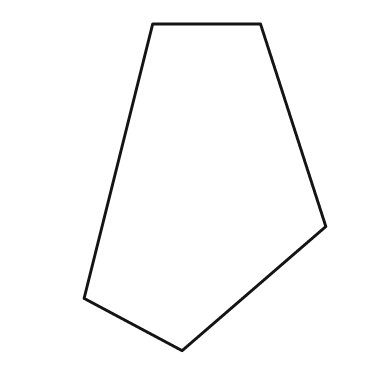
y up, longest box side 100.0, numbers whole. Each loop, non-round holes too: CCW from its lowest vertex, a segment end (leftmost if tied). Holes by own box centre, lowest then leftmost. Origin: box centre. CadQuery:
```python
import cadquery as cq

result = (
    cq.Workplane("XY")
    .moveTo(-7.0, -50.0)
    .lineTo(37.0, -12.0)
    .lineTo(17.0, 50.0)
    .lineTo(-16.0, 50.0)
    .lineTo(-37.0, -34.0)
    .close()
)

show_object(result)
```